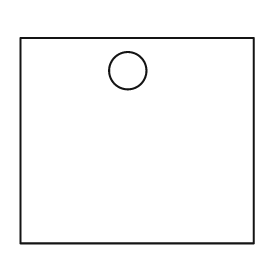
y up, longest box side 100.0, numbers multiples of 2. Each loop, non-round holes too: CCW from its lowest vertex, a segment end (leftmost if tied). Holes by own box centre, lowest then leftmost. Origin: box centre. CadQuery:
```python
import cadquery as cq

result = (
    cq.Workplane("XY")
    .moveTo(-50.0, -44.0)
    .lineTo(50.0, -44.0)
    .lineTo(50.0, 44.0)
    .lineTo(-50.0, 44.0)
    .close()
    .moveTo(-4.0, 30.0)
    .circle(8.0)
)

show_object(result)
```